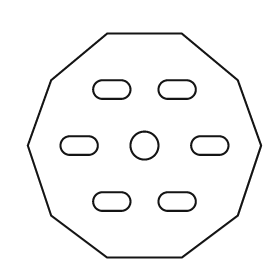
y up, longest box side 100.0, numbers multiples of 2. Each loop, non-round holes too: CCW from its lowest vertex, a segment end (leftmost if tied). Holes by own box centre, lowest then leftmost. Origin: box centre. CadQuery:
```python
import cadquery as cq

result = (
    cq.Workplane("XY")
    .moveTo(-16.0, -48.0)
    .lineTo(16.0, -48.0)
    .lineTo(40.0, -30.0)
    .lineTo(50.0, 0.0)
    .lineTo(40.0, 28.0)
    .lineTo(16.0, 48.0)
    .lineTo(-16.0, 48.0)
    .lineTo(-40.0, 28.0)
    .lineTo(-50.0, 0.0)
    .lineTo(-40.0, -30.0)
    .close()
    .moveTo(-18.0, -28.0)
    .lineTo(-10.0, -28.0)
    .threePointArc((-6.0, -24.0), (-10.0, -20.0))
    .lineTo(-18.0, -20.0)
    .threePointArc((-22.0, -24.0), (-18.0, -28.0))
    .close()
    .moveTo(10.0, -28.0)
    .lineTo(18.0, -28.0)
    .threePointArc((22.0, -24.0), (18.0, -20.0))
    .lineTo(10.0, -20.0)
    .threePointArc((6.0, -24.0), (10.0, -28.0))
    .close()
    .moveTo(-32.0, -4.0)
    .lineTo(-24.0, -4.0)
    .threePointArc((-20.0, 0.0), (-24.0, 4.0))
    .lineTo(-32.0, 4.0)
    .threePointArc((-36.0, 0.0), (-32.0, -4.0))
    .close()
    .moveTo(0.0, 0.0)
    .circle(6.0)
    .moveTo(24.0, -4.0)
    .lineTo(32.0, -4.0)
    .threePointArc((36.0, 0.0), (32.0, 4.0))
    .lineTo(24.0, 4.0)
    .threePointArc((20.0, 0.0), (24.0, -4.0))
    .close()
    .moveTo(-18.0, 20.0)
    .lineTo(-10.0, 20.0)
    .threePointArc((-6.0, 24.0), (-10.0, 28.0))
    .lineTo(-18.0, 28.0)
    .threePointArc((-22.0, 24.0), (-18.0, 20.0))
    .close()
    .moveTo(10.0, 20.0)
    .lineTo(18.0, 20.0)
    .threePointArc((22.0, 24.0), (18.0, 28.0))
    .lineTo(10.0, 28.0)
    .threePointArc((6.0, 24.0), (10.0, 20.0))
    .close()
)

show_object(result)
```